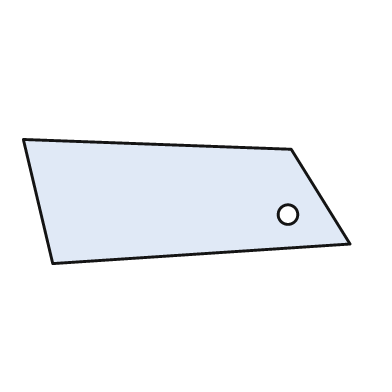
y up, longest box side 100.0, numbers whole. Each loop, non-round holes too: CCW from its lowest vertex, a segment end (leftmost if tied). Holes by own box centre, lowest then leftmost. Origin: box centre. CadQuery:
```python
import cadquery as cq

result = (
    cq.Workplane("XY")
    .moveTo(-41.0, -19.0)
    .lineTo(50.0, -13.0)
    .lineTo(32.0, 16.0)
    .lineTo(-50.0, 19.0)
    .close()
    .moveTo(31.0, -4.0)
    .circle(3.0)
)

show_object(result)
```